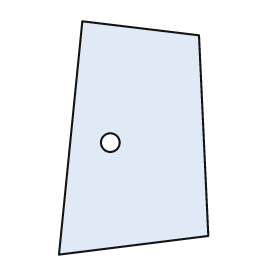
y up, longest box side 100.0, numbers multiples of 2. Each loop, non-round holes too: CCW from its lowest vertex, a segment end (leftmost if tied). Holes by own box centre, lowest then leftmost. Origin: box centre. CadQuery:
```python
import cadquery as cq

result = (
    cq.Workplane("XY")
    .moveTo(-32.0, -50.0)
    .lineTo(32.0, -42.0)
    .lineTo(28.0, 44.0)
    .lineTo(-22.0, 50.0)
    .close()
    .moveTo(-10.0, -2.0)
    .circle(4.0)
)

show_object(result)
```